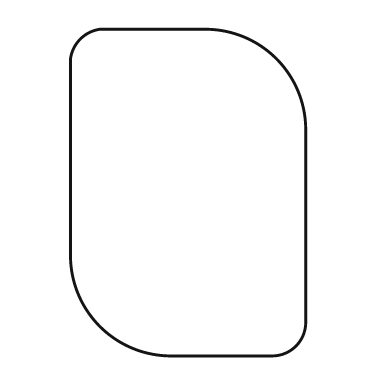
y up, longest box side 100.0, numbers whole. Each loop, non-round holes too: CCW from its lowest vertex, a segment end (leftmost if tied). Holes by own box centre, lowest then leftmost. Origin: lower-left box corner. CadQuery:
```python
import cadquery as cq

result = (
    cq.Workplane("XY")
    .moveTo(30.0, 0.0)
    .lineTo(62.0, 0.0)
    .threePointArc((69.0, 3.0), (72.0, 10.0))
    .lineTo(72.0, 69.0)
    .threePointArc((63.0, 91.0), (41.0, 100.0))
    .lineTo(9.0, 100.0)
    .threePointArc((3.0, 97.0), (0.0, 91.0))
    .lineTo(0.0, 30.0)
    .threePointArc((9.0, 9.0), (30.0, 0.0))
    .close()
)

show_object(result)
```